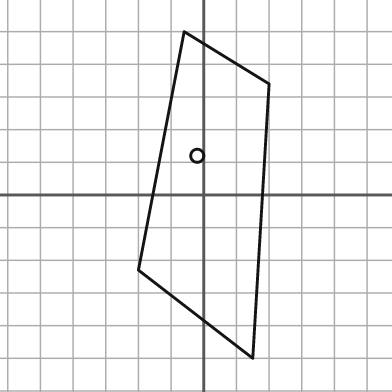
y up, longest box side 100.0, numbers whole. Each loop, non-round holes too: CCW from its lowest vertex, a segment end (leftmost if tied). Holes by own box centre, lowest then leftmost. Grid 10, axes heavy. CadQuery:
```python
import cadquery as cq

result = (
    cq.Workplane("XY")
    .moveTo(15.0, -50.0)
    .lineTo(20.0, 34.0)
    .lineTo(-6.0, 50.0)
    .lineTo(-20.0, -23.0)
    .close()
    .moveTo(-2.0, 12.0)
    .circle(2.0)
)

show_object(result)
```